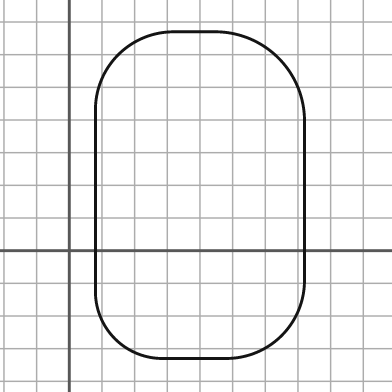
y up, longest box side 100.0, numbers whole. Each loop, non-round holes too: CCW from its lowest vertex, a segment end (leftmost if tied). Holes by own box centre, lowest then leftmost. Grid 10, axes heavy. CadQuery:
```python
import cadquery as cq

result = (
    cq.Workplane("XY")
    .moveTo(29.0, -33.0)
    .lineTo(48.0, -33.0)
    .threePointArc((65.0, -26.0), (72.0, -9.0))
    .lineTo(72.0, 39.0)
    .threePointArc((64.0, 59.0), (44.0, 67.0))
    .lineTo(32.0, 67.0)
    .threePointArc((15.0, 60.0), (8.0, 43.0))
    .lineTo(8.0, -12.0)
    .threePointArc((14.0, -27.0), (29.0, -33.0))
    .close()
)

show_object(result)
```